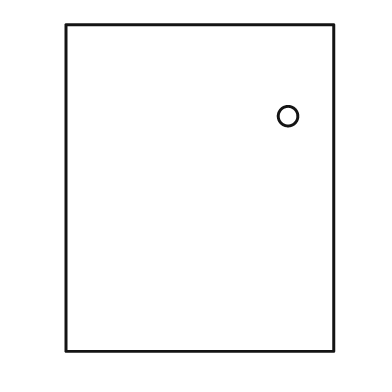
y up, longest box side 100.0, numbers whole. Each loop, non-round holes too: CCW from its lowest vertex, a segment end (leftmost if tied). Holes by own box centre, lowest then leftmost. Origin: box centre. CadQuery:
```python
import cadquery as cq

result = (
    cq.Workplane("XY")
    .moveTo(-41.0, -50.0)
    .lineTo(41.0, -50.0)
    .lineTo(41.0, 50.0)
    .lineTo(-41.0, 50.0)
    .close()
    .moveTo(27.0, 22.0)
    .circle(3.0)
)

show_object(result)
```